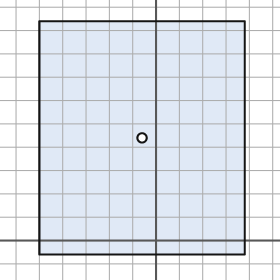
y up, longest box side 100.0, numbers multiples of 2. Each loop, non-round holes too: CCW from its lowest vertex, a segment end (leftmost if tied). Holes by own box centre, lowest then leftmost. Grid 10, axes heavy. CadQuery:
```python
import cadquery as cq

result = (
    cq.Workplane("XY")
    .moveTo(-50.0, -6.0)
    .lineTo(38.0, -6.0)
    .lineTo(38.0, 94.0)
    .lineTo(-50.0, 94.0)
    .close()
    .moveTo(-6.0, 44.0)
    .circle(2.0)
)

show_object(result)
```